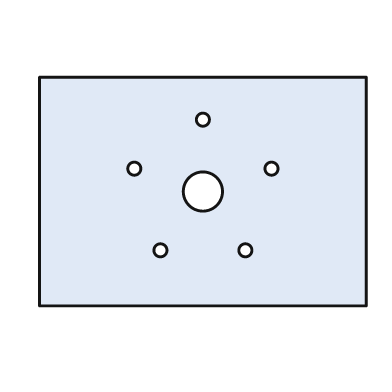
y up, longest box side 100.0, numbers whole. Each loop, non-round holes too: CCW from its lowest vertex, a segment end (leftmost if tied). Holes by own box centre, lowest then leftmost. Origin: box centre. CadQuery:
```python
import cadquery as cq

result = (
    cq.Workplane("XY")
    .moveTo(-50.0, -35.0)
    .lineTo(50.0, -35.0)
    .lineTo(50.0, 35.0)
    .lineTo(-50.0, 35.0)
    .close()
    .moveTo(-13.0, -18.0)
    .circle(2.0)
    .moveTo(13.0, -18.0)
    .circle(2.0)
    .moveTo(0.0, 0.0)
    .circle(6.0)
    .moveTo(-21.0, 7.0)
    .circle(2.0)
    .moveTo(21.0, 7.0)
    .circle(2.0)
    .moveTo(0.0, 22.0)
    .circle(2.0)
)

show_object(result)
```